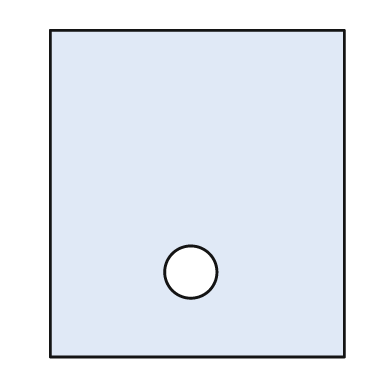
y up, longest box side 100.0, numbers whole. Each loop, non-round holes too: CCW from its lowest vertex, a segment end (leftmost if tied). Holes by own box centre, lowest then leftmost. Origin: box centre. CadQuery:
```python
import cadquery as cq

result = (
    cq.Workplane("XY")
    .moveTo(-45.0, -50.0)
    .lineTo(45.0, -50.0)
    .lineTo(45.0, 50.0)
    .lineTo(-45.0, 50.0)
    .close()
    .moveTo(-2.0, -24.0)
    .circle(8.0)
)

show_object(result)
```